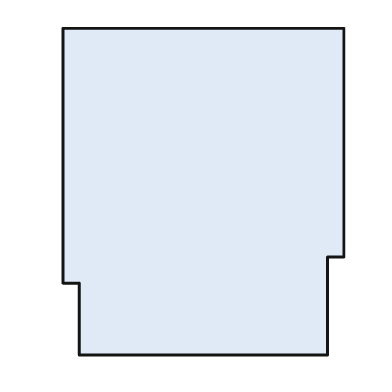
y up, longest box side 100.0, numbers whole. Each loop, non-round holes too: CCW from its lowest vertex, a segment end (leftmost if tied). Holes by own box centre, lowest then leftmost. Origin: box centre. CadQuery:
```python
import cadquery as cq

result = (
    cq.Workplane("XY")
    .moveTo(-38.0, -50.0)
    .lineTo(38.0, -50.0)
    .lineTo(38.0, -20.0)
    .lineTo(43.0, -20.0)
    .lineTo(43.0, 50.0)
    .lineTo(-43.0, 50.0)
    .lineTo(-43.0, -28.0)
    .lineTo(-38.0, -28.0)
    .close()
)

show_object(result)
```